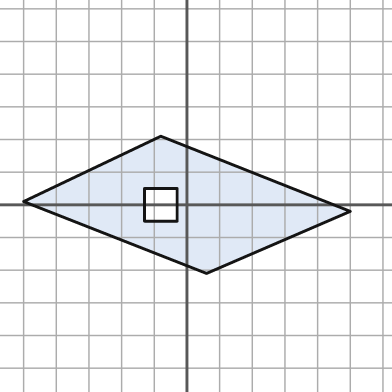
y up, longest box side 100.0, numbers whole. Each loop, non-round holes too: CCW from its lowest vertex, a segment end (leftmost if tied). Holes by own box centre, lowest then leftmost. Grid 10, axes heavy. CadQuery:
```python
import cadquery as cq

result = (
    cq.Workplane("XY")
    .moveTo(6.0, -21.0)
    .lineTo(50.0, -2.0)
    .lineTo(-8.0, 21.0)
    .lineTo(-50.0, 1.0)
    .close()
    .moveTo(-13.0, -5.0)
    .lineTo(-3.0, -5.0)
    .lineTo(-3.0, 5.0)
    .lineTo(-13.0, 5.0)
    .close()
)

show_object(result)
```